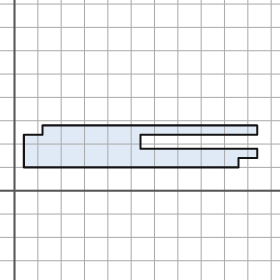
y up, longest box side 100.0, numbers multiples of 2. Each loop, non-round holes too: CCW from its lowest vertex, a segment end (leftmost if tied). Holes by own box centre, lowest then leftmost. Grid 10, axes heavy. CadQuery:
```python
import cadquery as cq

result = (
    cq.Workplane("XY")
    .moveTo(4.0, 10.0)
    .lineTo(96.0, 10.0)
    .lineTo(96.0, 14.0)
    .lineTo(104.0, 14.0)
    .lineTo(104.0, 18.0)
    .lineTo(54.0, 18.0)
    .lineTo(54.0, 24.0)
    .lineTo(104.0, 24.0)
    .lineTo(104.0, 28.0)
    .lineTo(12.0, 28.0)
    .lineTo(12.0, 24.0)
    .lineTo(4.0, 24.0)
    .close()
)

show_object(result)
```